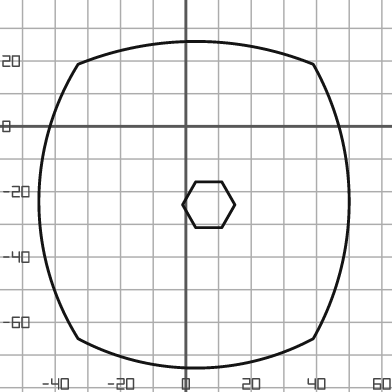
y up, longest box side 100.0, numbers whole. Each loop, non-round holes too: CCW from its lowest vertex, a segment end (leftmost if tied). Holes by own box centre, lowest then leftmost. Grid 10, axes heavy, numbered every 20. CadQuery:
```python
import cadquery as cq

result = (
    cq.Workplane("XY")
    .moveTo(-33.0, -65.0)
    .threePointArc((3.0, -74.0), (39.0, -65.0))
    .threePointArc((50.0, -23.0), (39.0, 19.0))
    .threePointArc((3.0, 26.0), (-33.0, 19.0))
    .threePointArc((-45.0, -23.0), (-33.0, -65.0))
    .close()
    .moveTo(3.0, -31.0)
    .lineTo(11.0, -31.0)
    .lineTo(15.0, -24.0)
    .lineTo(11.0, -17.0)
    .lineTo(3.0, -17.0)
    .lineTo(-1.0, -24.0)
    .close()
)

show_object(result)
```